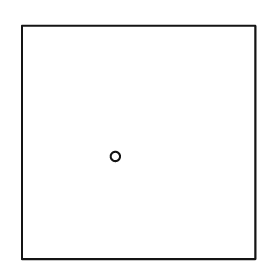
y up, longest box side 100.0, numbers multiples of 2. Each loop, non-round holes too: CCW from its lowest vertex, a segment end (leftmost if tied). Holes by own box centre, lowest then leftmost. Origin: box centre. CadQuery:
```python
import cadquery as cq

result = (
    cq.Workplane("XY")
    .moveTo(-50.0, -50.0)
    .lineTo(50.0, -50.0)
    .lineTo(50.0, 50.0)
    .lineTo(-50.0, 50.0)
    .close()
    .moveTo(-10.0, -6.0)
    .circle(2.0)
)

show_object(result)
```